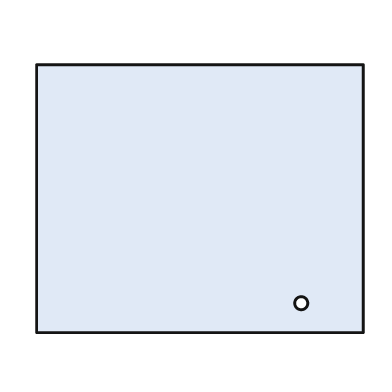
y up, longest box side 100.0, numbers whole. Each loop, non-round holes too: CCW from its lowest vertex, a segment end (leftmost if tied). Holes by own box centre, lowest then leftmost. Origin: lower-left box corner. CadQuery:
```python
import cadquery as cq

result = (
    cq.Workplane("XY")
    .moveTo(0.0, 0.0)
    .lineTo(100.0, 0.0)
    .lineTo(100.0, 82.0)
    .lineTo(0.0, 82.0)
    .close()
    .moveTo(81.0, 9.0)
    .circle(2.0)
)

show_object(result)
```